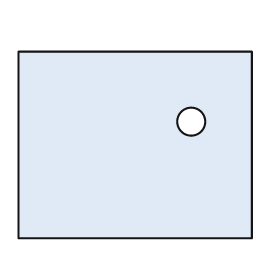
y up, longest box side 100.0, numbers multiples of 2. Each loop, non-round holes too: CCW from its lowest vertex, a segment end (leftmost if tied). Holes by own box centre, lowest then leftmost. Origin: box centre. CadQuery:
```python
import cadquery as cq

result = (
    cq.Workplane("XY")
    .moveTo(-50.0, -40.0)
    .lineTo(50.0, -40.0)
    .lineTo(50.0, 40.0)
    .lineTo(-50.0, 40.0)
    .close()
    .moveTo(24.0, 10.0)
    .circle(6.0)
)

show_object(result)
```